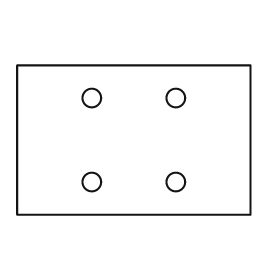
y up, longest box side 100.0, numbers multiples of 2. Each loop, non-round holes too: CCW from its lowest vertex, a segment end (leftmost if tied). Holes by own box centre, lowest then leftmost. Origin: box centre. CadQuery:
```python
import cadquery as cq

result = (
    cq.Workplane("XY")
    .moveTo(-50.0, -32.0)
    .lineTo(50.0, -32.0)
    .lineTo(50.0, 32.0)
    .lineTo(-50.0, 32.0)
    .close()
    .moveTo(-18.0, -18.0)
    .circle(4.0)
    .moveTo(18.0, -18.0)
    .circle(4.0)
    .moveTo(-18.0, 18.0)
    .circle(4.0)
    .moveTo(18.0, 18.0)
    .circle(4.0)
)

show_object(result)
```